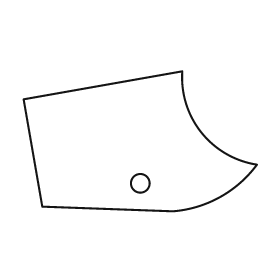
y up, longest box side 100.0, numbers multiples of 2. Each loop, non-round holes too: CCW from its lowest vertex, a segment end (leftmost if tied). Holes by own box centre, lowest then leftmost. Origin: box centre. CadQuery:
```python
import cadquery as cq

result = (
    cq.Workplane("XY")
    .moveTo(14.0, -30.0)
    .threePointArc((34.0, -24.0), (50.0, -10.0))
    .threePointArc((26.0, 4.0), (18.0, 30.0))
    .lineTo(-50.0, 18.0)
    .lineTo(-42.0, -28.0)
    .close()
    .moveTo(0.0, -18.0)
    .circle(4.0)
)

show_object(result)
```